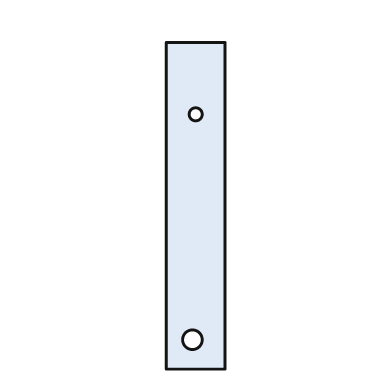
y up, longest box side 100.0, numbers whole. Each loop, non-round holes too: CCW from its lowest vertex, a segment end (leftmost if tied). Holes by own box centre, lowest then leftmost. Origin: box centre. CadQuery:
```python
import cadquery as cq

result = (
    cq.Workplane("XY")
    .moveTo(-9.0, -50.0)
    .lineTo(9.0, -50.0)
    .lineTo(9.0, 50.0)
    .lineTo(-9.0, 50.0)
    .close()
    .moveTo(-1.0, -41.0)
    .circle(3.0)
    .moveTo(0.0, 28.0)
    .circle(2.0)
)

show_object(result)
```